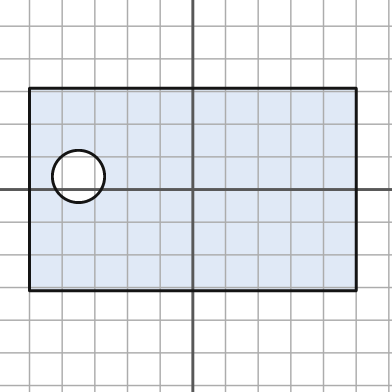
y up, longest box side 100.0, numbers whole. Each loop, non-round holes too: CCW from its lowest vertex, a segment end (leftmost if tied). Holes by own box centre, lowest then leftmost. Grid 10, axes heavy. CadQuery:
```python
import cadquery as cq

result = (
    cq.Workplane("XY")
    .moveTo(-50.0, -31.0)
    .lineTo(50.0, -31.0)
    .lineTo(50.0, 31.0)
    .lineTo(-50.0, 31.0)
    .close()
    .moveTo(-35.0, 4.0)
    .circle(8.0)
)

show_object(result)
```